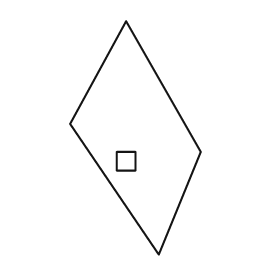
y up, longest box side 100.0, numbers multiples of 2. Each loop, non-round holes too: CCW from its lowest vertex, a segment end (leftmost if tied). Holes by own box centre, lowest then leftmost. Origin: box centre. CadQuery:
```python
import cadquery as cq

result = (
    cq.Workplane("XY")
    .moveTo(10.0, -50.0)
    .lineTo(28.0, -6.0)
    .lineTo(-4.0, 50.0)
    .lineTo(-28.0, 6.0)
    .close()
    .moveTo(-8.0, -14.0)
    .lineTo(0.0, -14.0)
    .lineTo(0.0, -6.0)
    .lineTo(-8.0, -6.0)
    .close()
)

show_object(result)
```